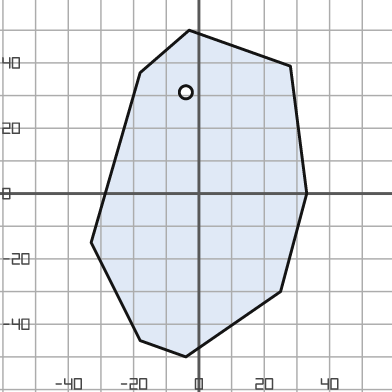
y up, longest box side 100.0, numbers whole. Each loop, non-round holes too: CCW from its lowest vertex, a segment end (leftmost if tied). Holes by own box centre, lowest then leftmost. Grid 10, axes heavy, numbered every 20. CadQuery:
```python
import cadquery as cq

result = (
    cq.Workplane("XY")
    .moveTo(-4.0, -50.0)
    .lineTo(25.0, -30.0)
    .lineTo(33.0, 0.0)
    .lineTo(28.0, 39.0)
    .lineTo(-3.0, 50.0)
    .lineTo(-18.0, 37.0)
    .lineTo(-33.0, -15.0)
    .lineTo(-18.0, -45.0)
    .close()
    .moveTo(-4.0, 31.0)
    .circle(2.0)
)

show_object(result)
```